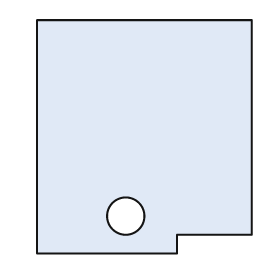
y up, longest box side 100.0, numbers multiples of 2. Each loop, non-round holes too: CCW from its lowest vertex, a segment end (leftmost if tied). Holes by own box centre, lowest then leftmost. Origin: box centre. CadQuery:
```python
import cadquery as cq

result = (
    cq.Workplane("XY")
    .moveTo(-46.0, -50.0)
    .lineTo(14.0, -50.0)
    .lineTo(14.0, -42.0)
    .lineTo(46.0, -42.0)
    .lineTo(46.0, 50.0)
    .lineTo(-46.0, 50.0)
    .close()
    .moveTo(-8.0, -34.0)
    .circle(8.0)
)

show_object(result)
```